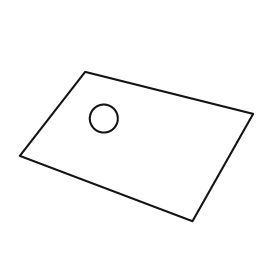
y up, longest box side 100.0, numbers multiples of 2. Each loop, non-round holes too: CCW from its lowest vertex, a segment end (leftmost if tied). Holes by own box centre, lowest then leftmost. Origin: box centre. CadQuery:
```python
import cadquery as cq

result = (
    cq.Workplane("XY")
    .moveTo(24.0, -32.0)
    .lineTo(50.0, 14.0)
    .lineTo(-22.0, 32.0)
    .lineTo(-50.0, -4.0)
    .close()
    .moveTo(-14.0, 12.0)
    .circle(6.0)
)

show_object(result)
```